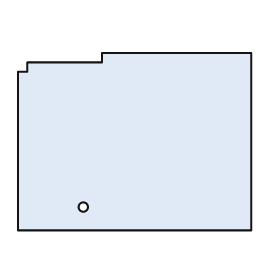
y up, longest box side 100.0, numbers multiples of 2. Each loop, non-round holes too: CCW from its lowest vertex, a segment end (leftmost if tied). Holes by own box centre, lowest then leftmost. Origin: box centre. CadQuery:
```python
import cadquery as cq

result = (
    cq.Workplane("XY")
    .moveTo(-50.0, -38.0)
    .lineTo(50.0, -38.0)
    .lineTo(50.0, 38.0)
    .lineTo(-14.0, 38.0)
    .lineTo(-14.0, 34.0)
    .lineTo(-46.0, 34.0)
    .lineTo(-46.0, 30.0)
    .lineTo(-50.0, 30.0)
    .close()
    .moveTo(-22.0, -28.0)
    .circle(2.0)
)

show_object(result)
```